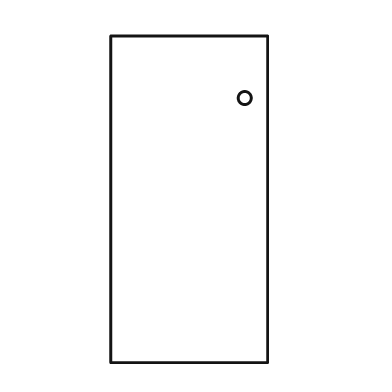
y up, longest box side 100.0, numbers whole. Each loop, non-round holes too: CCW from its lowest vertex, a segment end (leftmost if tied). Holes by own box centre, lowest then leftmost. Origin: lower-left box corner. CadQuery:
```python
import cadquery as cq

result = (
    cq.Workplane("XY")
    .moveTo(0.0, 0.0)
    .lineTo(48.0, 0.0)
    .lineTo(48.0, 100.0)
    .lineTo(0.0, 100.0)
    .close()
    .moveTo(41.0, 81.0)
    .circle(2.0)
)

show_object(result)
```